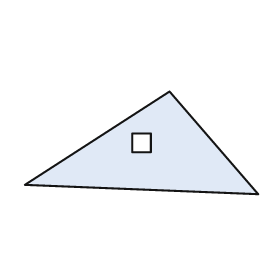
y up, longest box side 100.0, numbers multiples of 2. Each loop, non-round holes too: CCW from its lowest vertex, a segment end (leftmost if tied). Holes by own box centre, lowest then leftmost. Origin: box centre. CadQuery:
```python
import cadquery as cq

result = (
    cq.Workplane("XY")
    .moveTo(50.0, -22.0)
    .lineTo(12.0, 22.0)
    .lineTo(-50.0, -18.0)
    .close()
    .moveTo(-4.0, -4.0)
    .lineTo(4.0, -4.0)
    .lineTo(4.0, 4.0)
    .lineTo(-4.0, 4.0)
    .close()
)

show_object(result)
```